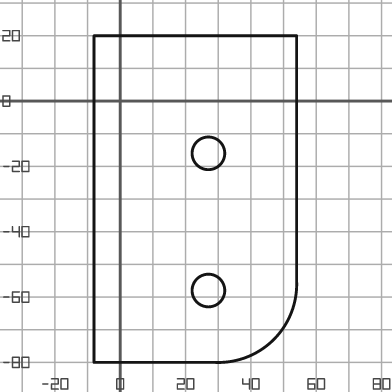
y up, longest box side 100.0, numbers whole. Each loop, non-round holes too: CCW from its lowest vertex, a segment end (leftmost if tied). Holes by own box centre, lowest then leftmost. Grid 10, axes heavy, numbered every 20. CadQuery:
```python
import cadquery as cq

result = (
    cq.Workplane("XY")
    .moveTo(-8.0, -80.0)
    .lineTo(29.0, -80.0)
    .threePointArc((47.0, -73.0), (54.0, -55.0))
    .lineTo(54.0, 20.0)
    .lineTo(-8.0, 20.0)
    .close()
    .moveTo(27.0, -58.0)
    .circle(5.0)
    .moveTo(27.0, -16.0)
    .circle(5.0)
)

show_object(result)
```